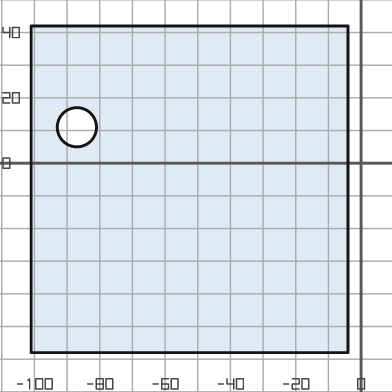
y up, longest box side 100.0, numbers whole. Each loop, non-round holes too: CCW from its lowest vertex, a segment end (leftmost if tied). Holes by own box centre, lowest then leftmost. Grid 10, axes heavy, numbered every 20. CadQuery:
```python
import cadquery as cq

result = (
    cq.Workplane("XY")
    .moveTo(-101.0, -58.0)
    .lineTo(-4.0, -58.0)
    .lineTo(-4.0, 42.0)
    .lineTo(-101.0, 42.0)
    .close()
    .moveTo(-87.0, 11.0)
    .circle(6.0)
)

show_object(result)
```